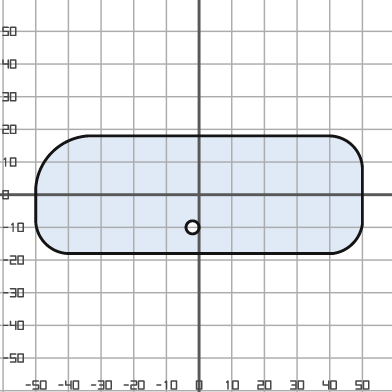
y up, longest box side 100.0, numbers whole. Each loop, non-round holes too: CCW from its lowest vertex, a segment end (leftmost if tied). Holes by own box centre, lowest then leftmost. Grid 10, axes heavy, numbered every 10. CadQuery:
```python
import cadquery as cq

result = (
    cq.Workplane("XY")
    .moveTo(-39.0, -18.0)
    .lineTo(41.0, -18.0)
    .threePointArc((47.0, -15.0), (50.0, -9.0))
    .lineTo(50.0, 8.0)
    .threePointArc((47.0, 15.0), (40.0, 18.0))
    .lineTo(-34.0, 18.0)
    .threePointArc((-45.0, 13.0), (-50.0, 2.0))
    .lineTo(-50.0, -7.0)
    .threePointArc((-47.0, -15.0), (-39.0, -18.0))
    .close()
    .moveTo(-2.0, -10.0)
    .circle(2.0)
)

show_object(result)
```